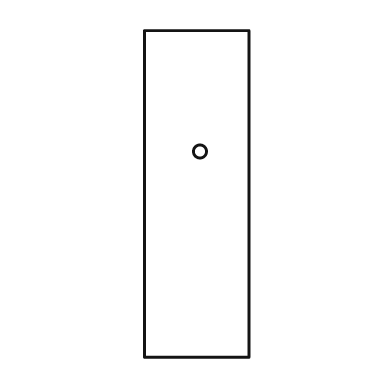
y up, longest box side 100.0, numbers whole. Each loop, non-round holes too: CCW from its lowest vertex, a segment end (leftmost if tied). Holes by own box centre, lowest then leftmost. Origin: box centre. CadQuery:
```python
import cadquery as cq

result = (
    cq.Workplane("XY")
    .moveTo(-16.0, -50.0)
    .lineTo(16.0, -50.0)
    .lineTo(16.0, 50.0)
    .lineTo(-16.0, 50.0)
    .close()
    .moveTo(1.0, 13.0)
    .circle(2.0)
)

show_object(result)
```